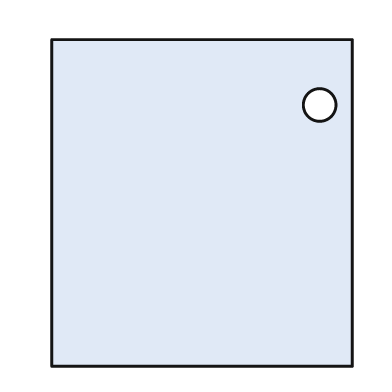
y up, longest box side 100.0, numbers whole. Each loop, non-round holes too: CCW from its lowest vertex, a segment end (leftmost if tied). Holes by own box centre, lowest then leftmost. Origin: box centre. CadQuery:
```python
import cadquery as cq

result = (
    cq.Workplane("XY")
    .moveTo(-46.0, -50.0)
    .lineTo(46.0, -50.0)
    .lineTo(46.0, 50.0)
    .lineTo(-46.0, 50.0)
    .close()
    .moveTo(36.0, 30.0)
    .circle(5.0)
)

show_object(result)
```